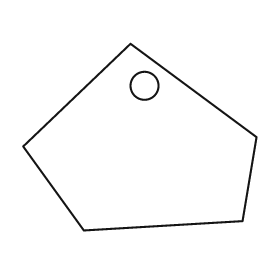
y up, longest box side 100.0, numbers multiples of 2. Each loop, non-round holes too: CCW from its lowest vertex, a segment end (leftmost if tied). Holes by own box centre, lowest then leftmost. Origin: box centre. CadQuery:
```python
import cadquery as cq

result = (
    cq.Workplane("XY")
    .moveTo(-24.0, -40.0)
    .lineTo(44.0, -36.0)
    .lineTo(50.0, 0.0)
    .lineTo(-4.0, 40.0)
    .lineTo(-50.0, -4.0)
    .close()
    .moveTo(2.0, 22.0)
    .circle(6.0)
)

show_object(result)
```